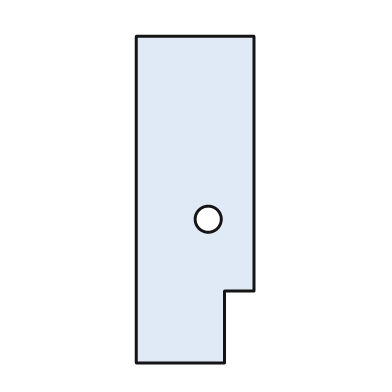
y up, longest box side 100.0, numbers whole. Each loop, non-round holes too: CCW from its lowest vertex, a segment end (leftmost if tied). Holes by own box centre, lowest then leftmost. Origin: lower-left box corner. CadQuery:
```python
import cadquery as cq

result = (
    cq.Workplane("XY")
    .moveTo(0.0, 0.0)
    .lineTo(27.0, 0.0)
    .lineTo(27.0, 22.0)
    .lineTo(36.0, 22.0)
    .lineTo(36.0, 100.0)
    .lineTo(0.0, 100.0)
    .close()
    .moveTo(22.0, 44.0)
    .circle(4.0)
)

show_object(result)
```